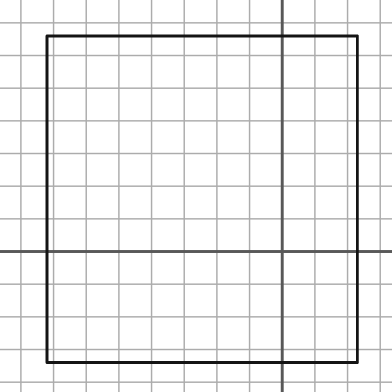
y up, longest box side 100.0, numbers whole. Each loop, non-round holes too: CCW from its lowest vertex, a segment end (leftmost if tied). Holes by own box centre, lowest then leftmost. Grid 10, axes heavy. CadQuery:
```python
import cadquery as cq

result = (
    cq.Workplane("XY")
    .moveTo(-72.0, -34.0)
    .lineTo(23.0, -34.0)
    .lineTo(23.0, 66.0)
    .lineTo(-72.0, 66.0)
    .close()
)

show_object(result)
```